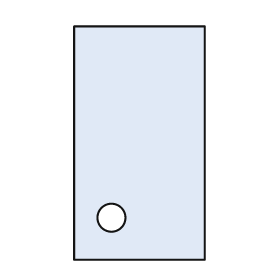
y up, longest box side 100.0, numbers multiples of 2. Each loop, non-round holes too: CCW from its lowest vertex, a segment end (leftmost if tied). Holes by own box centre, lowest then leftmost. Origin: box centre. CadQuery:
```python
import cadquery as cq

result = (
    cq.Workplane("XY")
    .moveTo(-28.0, -50.0)
    .lineTo(28.0, -50.0)
    .lineTo(28.0, 50.0)
    .lineTo(-28.0, 50.0)
    .close()
    .moveTo(-12.0, -32.0)
    .circle(6.0)
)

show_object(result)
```